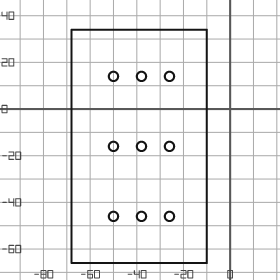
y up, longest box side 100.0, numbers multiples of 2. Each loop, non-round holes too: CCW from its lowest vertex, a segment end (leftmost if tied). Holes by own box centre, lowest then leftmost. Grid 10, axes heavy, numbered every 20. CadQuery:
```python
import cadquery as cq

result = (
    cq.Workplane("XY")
    .moveTo(-68.0, -66.0)
    .lineTo(-10.0, -66.0)
    .lineTo(-10.0, 34.0)
    .lineTo(-68.0, 34.0)
    .close()
    .moveTo(-50.0, -46.0)
    .circle(2.0)
    .moveTo(-38.0, -46.0)
    .circle(2.0)
    .moveTo(-26.0, -46.0)
    .circle(2.0)
    .moveTo(-50.0, -16.0)
    .circle(2.0)
    .moveTo(-38.0, -16.0)
    .circle(2.0)
    .moveTo(-26.0, -16.0)
    .circle(2.0)
    .moveTo(-50.0, 14.0)
    .circle(2.0)
    .moveTo(-38.0, 14.0)
    .circle(2.0)
    .moveTo(-26.0, 14.0)
    .circle(2.0)
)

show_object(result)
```